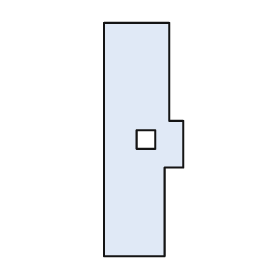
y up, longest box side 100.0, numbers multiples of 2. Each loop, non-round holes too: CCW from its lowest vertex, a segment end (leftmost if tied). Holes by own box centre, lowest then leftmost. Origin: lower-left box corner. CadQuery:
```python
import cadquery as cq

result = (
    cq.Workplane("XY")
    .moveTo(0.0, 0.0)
    .lineTo(26.0, 0.0)
    .lineTo(26.0, 38.0)
    .lineTo(34.0, 38.0)
    .lineTo(34.0, 58.0)
    .lineTo(28.0, 58.0)
    .lineTo(28.0, 100.0)
    .lineTo(0.0, 100.0)
    .close()
    .moveTo(14.0, 46.0)
    .lineTo(22.0, 46.0)
    .lineTo(22.0, 54.0)
    .lineTo(14.0, 54.0)
    .close()
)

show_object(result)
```